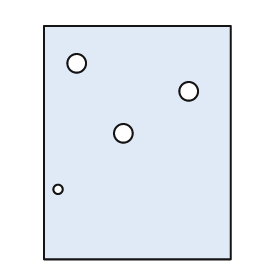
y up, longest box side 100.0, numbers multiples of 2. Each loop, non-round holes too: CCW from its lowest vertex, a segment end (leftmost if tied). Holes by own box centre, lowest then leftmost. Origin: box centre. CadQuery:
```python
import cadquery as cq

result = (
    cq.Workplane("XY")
    .moveTo(-40.0, -50.0)
    .lineTo(40.0, -50.0)
    .lineTo(40.0, 50.0)
    .lineTo(-40.0, 50.0)
    .close()
    .moveTo(-34.0, -20.0)
    .circle(2.0)
    .moveTo(-6.0, 4.0)
    .circle(4.0)
    .moveTo(22.0, 22.0)
    .circle(4.0)
    .moveTo(-26.0, 34.0)
    .circle(4.0)
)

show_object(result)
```